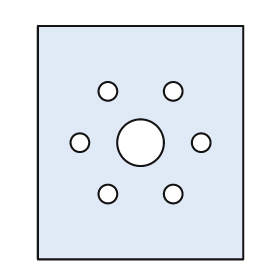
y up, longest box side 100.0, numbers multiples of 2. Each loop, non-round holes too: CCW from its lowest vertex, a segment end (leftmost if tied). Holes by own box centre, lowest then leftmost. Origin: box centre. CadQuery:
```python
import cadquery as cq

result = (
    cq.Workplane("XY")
    .moveTo(-44.0, -50.0)
    .lineTo(44.0, -50.0)
    .lineTo(44.0, 50.0)
    .lineTo(-44.0, 50.0)
    .close()
    .moveTo(-14.0, -22.0)
    .circle(4.0)
    .moveTo(14.0, -22.0)
    .circle(4.0)
    .moveTo(-26.0, 0.0)
    .circle(4.0)
    .moveTo(0.0, 0.0)
    .circle(10.0)
    .moveTo(26.0, 0.0)
    .circle(4.0)
    .moveTo(-14.0, 22.0)
    .circle(4.0)
    .moveTo(14.0, 22.0)
    .circle(4.0)
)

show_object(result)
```